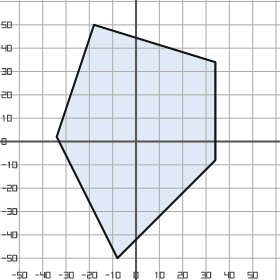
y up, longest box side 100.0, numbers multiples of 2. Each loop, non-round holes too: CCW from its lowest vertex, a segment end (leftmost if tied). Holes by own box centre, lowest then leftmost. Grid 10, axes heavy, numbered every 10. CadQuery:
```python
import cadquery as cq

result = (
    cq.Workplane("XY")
    .moveTo(-8.0, -50.0)
    .lineTo(34.0, -8.0)
    .lineTo(34.0, 34.0)
    .lineTo(-18.0, 50.0)
    .lineTo(-34.0, 2.0)
    .close()
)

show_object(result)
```